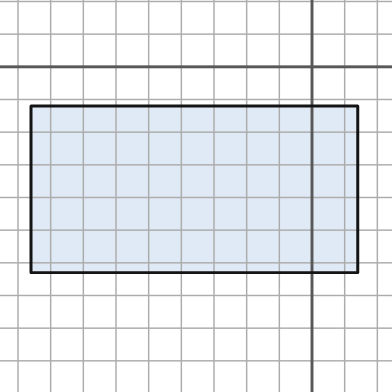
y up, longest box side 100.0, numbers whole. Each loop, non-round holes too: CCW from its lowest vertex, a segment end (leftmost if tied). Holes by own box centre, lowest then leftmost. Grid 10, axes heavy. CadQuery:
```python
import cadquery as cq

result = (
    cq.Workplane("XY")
    .moveTo(-86.0, -63.0)
    .lineTo(14.0, -63.0)
    .lineTo(14.0, -12.0)
    .lineTo(-86.0, -12.0)
    .close()
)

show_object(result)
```